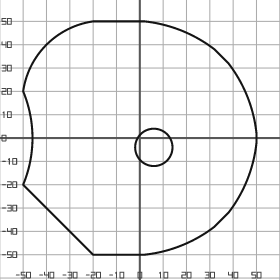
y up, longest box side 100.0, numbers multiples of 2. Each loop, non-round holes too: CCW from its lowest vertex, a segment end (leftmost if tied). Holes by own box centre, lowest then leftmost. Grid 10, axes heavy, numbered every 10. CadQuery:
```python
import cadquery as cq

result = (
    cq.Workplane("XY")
    .moveTo(-20.0, -50.0)
    .lineTo(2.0, -50.0)
    .threePointArc((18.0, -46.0), (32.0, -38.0))
    .lineTo(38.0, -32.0)
    .threePointArc((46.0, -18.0), (50.0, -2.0))
    .lineTo(50.0, 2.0)
    .threePointArc((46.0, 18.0), (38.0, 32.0))
    .lineTo(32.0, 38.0)
    .threePointArc((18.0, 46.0), (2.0, 50.0))
    .lineTo(-20.0, 50.0)
    .threePointArc((-40.0, 40.0), (-50.0, 20.0))
    .threePointArc((-46.0, 0.0), (-50.0, -20.0))
    .close()
    .moveTo(6.0, -4.0)
    .circle(8.0)
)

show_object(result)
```